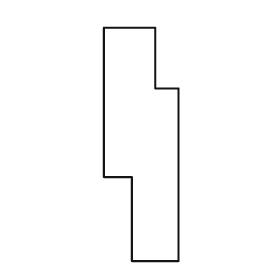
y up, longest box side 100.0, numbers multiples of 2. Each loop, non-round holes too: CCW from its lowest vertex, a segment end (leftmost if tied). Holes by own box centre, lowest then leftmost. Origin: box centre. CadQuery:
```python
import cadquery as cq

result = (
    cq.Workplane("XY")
    .moveTo(-4.0, -50.0)
    .lineTo(16.0, -50.0)
    .lineTo(16.0, 24.0)
    .lineTo(6.0, 24.0)
    .lineTo(6.0, 50.0)
    .lineTo(-16.0, 50.0)
    .lineTo(-16.0, -14.0)
    .lineTo(-4.0, -14.0)
    .close()
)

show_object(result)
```